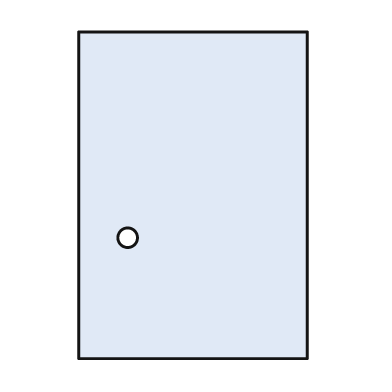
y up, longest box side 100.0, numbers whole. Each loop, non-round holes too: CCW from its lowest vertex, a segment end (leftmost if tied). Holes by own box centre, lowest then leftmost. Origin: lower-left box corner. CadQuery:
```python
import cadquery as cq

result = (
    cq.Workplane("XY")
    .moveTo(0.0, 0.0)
    .lineTo(70.0, 0.0)
    .lineTo(70.0, 100.0)
    .lineTo(0.0, 100.0)
    .close()
    .moveTo(15.0, 37.0)
    .circle(3.0)
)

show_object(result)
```